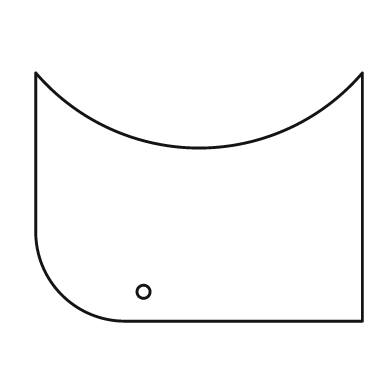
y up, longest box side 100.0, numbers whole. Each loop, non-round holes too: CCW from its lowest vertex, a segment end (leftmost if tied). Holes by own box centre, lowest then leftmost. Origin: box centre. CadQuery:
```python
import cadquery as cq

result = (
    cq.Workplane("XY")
    .moveTo(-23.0, -38.0)
    .lineTo(50.0, -38.0)
    .lineTo(50.0, 38.0)
    .threePointArc((0.0, 15.0), (-50.0, 38.0))
    .lineTo(-50.0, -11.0)
    .threePointArc((-42.0, -30.0), (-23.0, -38.0))
    .close()
    .moveTo(-17.0, -29.0)
    .circle(2.0)
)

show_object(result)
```